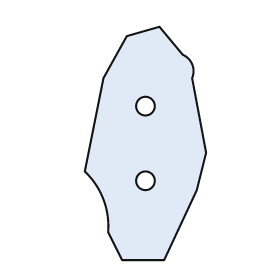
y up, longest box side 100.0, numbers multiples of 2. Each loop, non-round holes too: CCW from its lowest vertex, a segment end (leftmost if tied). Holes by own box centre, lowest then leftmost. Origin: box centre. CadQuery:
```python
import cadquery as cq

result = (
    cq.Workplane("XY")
    .moveTo(-10.0, -50.0)
    .lineTo(8.0, -50.0)
    .lineTo(22.0, -20.0)
    .lineTo(26.0, -4.0)
    .lineTo(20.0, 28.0)
    .threePointArc((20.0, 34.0), (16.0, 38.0))
    .lineTo(6.0, 50.0)
    .lineTo(-8.0, 46.0)
    .lineTo(-18.0, 28.0)
    .lineTo(-26.0, -12.0)
    .threePointArc((-18.0, -24.0), (-16.0, -38.0))
    .close()
    .moveTo(0.0, -16.0)
    .circle(4.0)
    .moveTo(0.0, 16.0)
    .circle(4.0)
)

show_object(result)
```